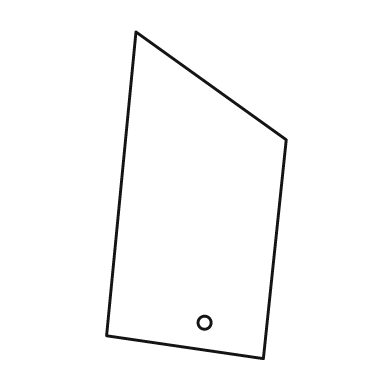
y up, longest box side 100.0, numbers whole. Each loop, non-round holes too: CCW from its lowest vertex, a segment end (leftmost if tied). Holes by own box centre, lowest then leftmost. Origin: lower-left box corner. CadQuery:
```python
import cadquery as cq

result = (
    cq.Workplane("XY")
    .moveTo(48.0, 0.0)
    .lineTo(55.0, 67.0)
    .lineTo(9.0, 100.0)
    .lineTo(0.0, 7.0)
    .close()
    .moveTo(30.0, 11.0)
    .circle(2.0)
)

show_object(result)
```